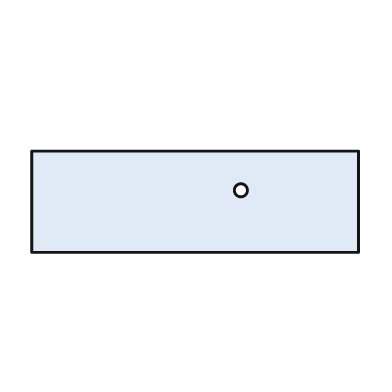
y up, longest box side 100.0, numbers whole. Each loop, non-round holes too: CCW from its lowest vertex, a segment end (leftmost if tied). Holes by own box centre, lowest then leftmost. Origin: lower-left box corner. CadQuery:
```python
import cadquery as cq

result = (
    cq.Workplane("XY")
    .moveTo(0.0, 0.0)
    .lineTo(100.0, 0.0)
    .lineTo(100.0, 31.0)
    .lineTo(0.0, 31.0)
    .close()
    .moveTo(64.0, 19.0)
    .circle(2.0)
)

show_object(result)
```